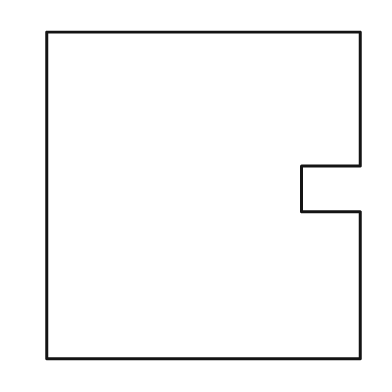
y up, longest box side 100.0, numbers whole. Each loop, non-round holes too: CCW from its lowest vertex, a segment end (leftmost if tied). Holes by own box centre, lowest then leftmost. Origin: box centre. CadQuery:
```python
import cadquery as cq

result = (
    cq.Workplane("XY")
    .moveTo(-48.0, -50.0)
    .lineTo(48.0, -50.0)
    .lineTo(48.0, -5.0)
    .lineTo(30.0, -5.0)
    .lineTo(30.0, 9.0)
    .lineTo(48.0, 9.0)
    .lineTo(48.0, 50.0)
    .lineTo(-48.0, 50.0)
    .close()
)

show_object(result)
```